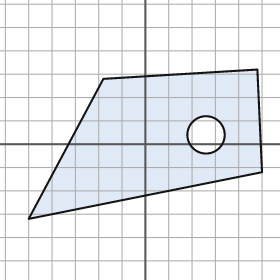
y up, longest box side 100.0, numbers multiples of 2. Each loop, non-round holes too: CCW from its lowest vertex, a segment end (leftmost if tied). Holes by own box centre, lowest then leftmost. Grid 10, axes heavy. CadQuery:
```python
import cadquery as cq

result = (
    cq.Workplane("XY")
    .moveTo(-50.0, -32.0)
    .lineTo(50.0, -12.0)
    .lineTo(48.0, 32.0)
    .lineTo(-18.0, 28.0)
    .close()
    .moveTo(26.0, 4.0)
    .circle(8.0)
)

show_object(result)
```